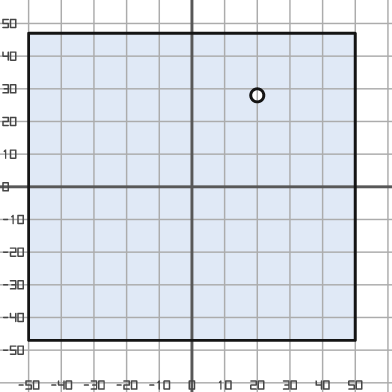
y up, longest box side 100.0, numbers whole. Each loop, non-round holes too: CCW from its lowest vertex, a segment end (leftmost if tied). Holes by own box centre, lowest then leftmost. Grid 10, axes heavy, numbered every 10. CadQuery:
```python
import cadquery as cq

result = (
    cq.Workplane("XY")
    .moveTo(-50.0, -47.0)
    .lineTo(50.0, -47.0)
    .lineTo(50.0, 47.0)
    .lineTo(-50.0, 47.0)
    .close()
    .moveTo(20.0, 28.0)
    .circle(2.0)
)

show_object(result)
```